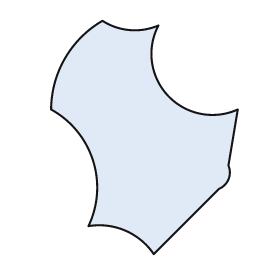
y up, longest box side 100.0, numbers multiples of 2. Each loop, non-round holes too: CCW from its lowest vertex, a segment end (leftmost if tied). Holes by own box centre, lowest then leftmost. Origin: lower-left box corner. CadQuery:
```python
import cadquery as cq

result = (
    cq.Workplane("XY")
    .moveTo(44.0, 0.0)
    .lineTo(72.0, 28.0)
    .threePointArc((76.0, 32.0), (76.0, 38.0))
    .lineTo(80.0, 62.0)
    .threePointArc((50.0, 68.0), (46.0, 98.0))
    .threePointArc((34.0, 96.0), (22.0, 100.0))
    .threePointArc((6.0, 84.0), (0.0, 62.0))
    .threePointArc((18.0, 40.0), (16.0, 12.0))
    .threePointArc((32.0, 10.0), (44.0, 0.0))
    .close()
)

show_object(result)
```